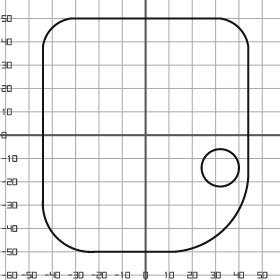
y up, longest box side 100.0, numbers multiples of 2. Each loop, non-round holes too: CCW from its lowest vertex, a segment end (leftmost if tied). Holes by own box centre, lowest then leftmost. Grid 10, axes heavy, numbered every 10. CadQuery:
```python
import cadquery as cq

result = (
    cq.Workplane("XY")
    .moveTo(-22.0, -50.0)
    .lineTo(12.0, -50.0)
    .threePointArc((34.0, -40.0), (44.0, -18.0))
    .lineTo(44.0, 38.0)
    .threePointArc((40.0, 46.0), (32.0, 50.0))
    .lineTo(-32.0, 50.0)
    .threePointArc((-40.0, 46.0), (-44.0, 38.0))
    .lineTo(-44.0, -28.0)
    .threePointArc((-38.0, -44.0), (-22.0, -50.0))
    .close()
    .moveTo(32.0, -14.0)
    .circle(8.0)
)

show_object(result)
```